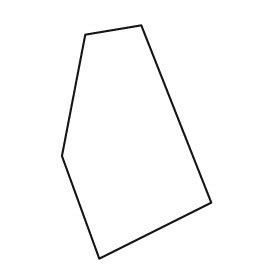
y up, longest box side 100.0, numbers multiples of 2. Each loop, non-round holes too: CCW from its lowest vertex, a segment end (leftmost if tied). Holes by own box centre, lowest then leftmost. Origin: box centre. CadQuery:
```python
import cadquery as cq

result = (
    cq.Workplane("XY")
    .moveTo(-16.0, -50.0)
    .lineTo(32.0, -26.0)
    .lineTo(2.0, 50.0)
    .lineTo(-22.0, 46.0)
    .lineTo(-32.0, -6.0)
    .close()
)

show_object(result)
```